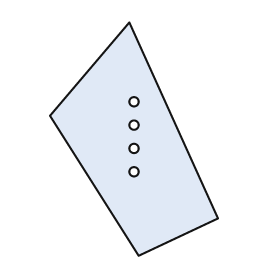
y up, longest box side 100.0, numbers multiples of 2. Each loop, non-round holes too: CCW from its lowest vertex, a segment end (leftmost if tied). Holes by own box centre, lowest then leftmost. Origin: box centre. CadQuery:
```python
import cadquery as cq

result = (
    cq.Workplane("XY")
    .moveTo(2.0, -50.0)
    .lineTo(36.0, -34.0)
    .lineTo(-2.0, 50.0)
    .lineTo(-36.0, 10.0)
    .close()
    .moveTo(0.0, -14.0)
    .circle(2.0)
    .moveTo(0.0, -4.0)
    .circle(2.0)
    .moveTo(0.0, 6.0)
    .circle(2.0)
    .moveTo(0.0, 16.0)
    .circle(2.0)
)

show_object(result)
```